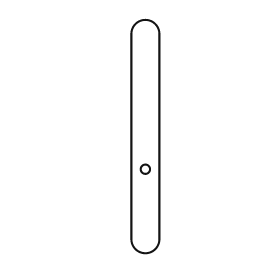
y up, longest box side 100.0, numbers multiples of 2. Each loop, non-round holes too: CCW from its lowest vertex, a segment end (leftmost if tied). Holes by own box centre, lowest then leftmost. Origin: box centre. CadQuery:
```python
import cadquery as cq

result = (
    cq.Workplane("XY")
    .moveTo(-6.0, -44.0)
    .threePointArc((0.0, -50.0), (6.0, -44.0))
    .lineTo(6.0, 44.0)
    .threePointArc((0.0, 50.0), (-6.0, 44.0))
    .close()
    .moveTo(0.0, -14.0)
    .circle(2.0)
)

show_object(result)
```